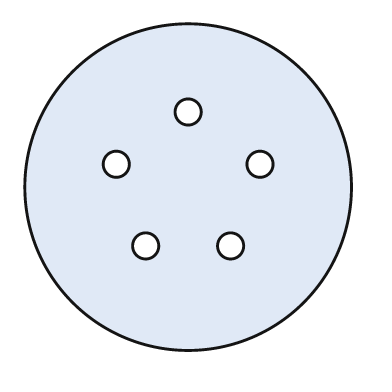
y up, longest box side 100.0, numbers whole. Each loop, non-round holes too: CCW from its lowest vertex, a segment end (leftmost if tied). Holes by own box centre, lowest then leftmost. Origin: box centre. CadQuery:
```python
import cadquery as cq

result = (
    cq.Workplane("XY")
    .moveTo(0.0, 0.0)
    .circle(50.0)
    .moveTo(-13.0, -18.0)
    .circle(4.0)
    .moveTo(13.0, -18.0)
    .circle(4.0)
    .moveTo(-22.0, 7.0)
    .circle(4.0)
    .moveTo(22.0, 7.0)
    .circle(4.0)
    .moveTo(0.0, 23.0)
    .circle(4.0)
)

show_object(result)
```